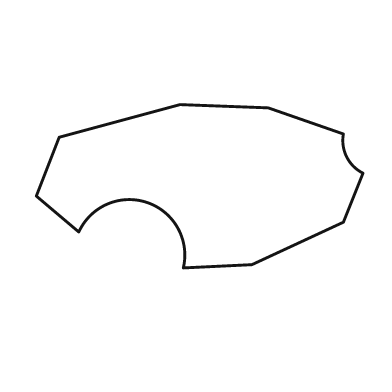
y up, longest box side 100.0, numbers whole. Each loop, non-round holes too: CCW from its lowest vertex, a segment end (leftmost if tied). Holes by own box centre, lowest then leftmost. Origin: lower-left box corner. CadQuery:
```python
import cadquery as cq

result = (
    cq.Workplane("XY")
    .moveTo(45.0, 0.0)
    .lineTo(66.0, 1.0)
    .lineTo(94.0, 14.0)
    .lineTo(100.0, 29.0)
    .threePointArc((95.0, 34.0), (94.0, 41.0))
    .lineTo(71.0, 49.0)
    .lineTo(44.0, 50.0)
    .lineTo(7.0, 40.0)
    .lineTo(0.0, 22.0)
    .lineTo(13.0, 11.0)
    .threePointArc((34.0, 20.0), (45.0, 0.0))
    .close()
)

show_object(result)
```